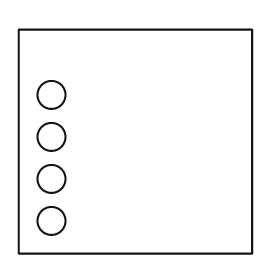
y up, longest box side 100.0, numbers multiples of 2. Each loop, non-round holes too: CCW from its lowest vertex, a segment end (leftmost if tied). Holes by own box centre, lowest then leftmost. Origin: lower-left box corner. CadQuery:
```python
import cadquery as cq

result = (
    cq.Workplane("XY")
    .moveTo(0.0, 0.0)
    .lineTo(100.0, 0.0)
    .lineTo(100.0, 96.0)
    .lineTo(0.0, 96.0)
    .close()
    .moveTo(14.0, 14.0)
    .circle(6.0)
    .moveTo(14.0, 32.0)
    .circle(6.0)
    .moveTo(14.0, 50.0)
    .circle(6.0)
    .moveTo(14.0, 68.0)
    .circle(6.0)
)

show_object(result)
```